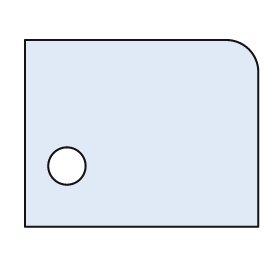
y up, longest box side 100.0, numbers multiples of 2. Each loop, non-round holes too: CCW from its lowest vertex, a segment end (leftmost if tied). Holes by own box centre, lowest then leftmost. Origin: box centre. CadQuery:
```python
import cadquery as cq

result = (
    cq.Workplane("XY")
    .moveTo(-50.0, -40.0)
    .lineTo(50.0, -40.0)
    .lineTo(50.0, 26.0)
    .threePointArc((46.0, 36.0), (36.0, 40.0))
    .lineTo(-50.0, 40.0)
    .close()
    .moveTo(-32.0, -14.0)
    .circle(8.0)
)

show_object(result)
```